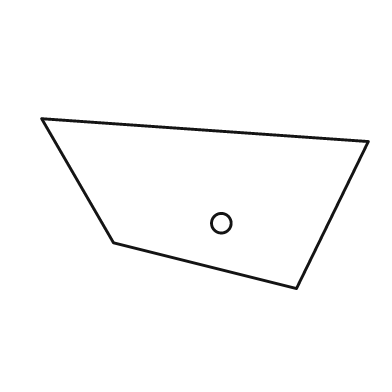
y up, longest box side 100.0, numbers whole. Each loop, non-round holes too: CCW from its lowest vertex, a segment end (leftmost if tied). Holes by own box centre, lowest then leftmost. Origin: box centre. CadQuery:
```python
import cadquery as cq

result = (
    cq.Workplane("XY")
    .moveTo(28.0, -26.0)
    .lineTo(50.0, 19.0)
    .lineTo(-50.0, 26.0)
    .lineTo(-28.0, -12.0)
    .close()
    .moveTo(5.0, -6.0)
    .circle(3.0)
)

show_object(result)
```